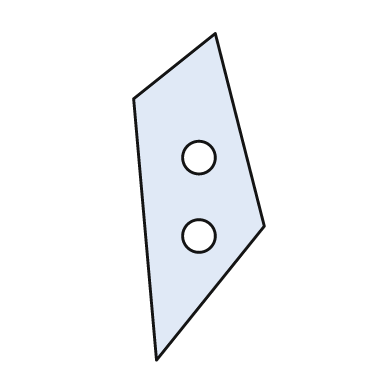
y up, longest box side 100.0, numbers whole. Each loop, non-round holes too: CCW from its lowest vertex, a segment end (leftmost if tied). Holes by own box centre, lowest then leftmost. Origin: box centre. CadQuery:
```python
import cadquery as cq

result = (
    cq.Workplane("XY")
    .moveTo(-13.0, -50.0)
    .lineTo(20.0, -9.0)
    .lineTo(5.0, 50.0)
    .lineTo(-20.0, 30.0)
    .close()
    .moveTo(0.0, -12.0)
    .circle(5.0)
    .moveTo(0.0, 12.0)
    .circle(5.0)
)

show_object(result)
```